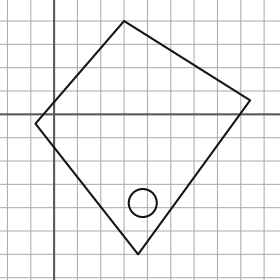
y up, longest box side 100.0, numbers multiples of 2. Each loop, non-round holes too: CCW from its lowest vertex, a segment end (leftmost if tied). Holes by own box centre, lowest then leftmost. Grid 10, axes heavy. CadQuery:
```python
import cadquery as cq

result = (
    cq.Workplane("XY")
    .moveTo(36.0, -60.0)
    .lineTo(84.0, 6.0)
    .lineTo(30.0, 40.0)
    .lineTo(-8.0, -4.0)
    .close()
    .moveTo(38.0, -38.0)
    .circle(6.0)
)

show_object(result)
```